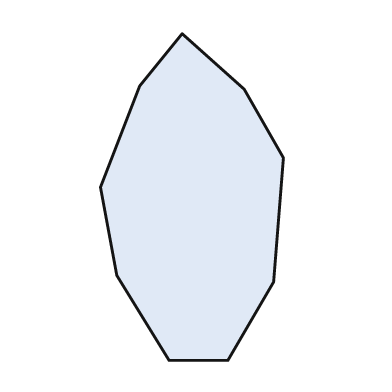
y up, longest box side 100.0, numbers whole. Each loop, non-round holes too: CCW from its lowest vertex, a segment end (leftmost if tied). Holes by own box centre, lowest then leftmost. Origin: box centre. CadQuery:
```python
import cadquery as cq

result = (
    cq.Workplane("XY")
    .moveTo(-7.0, -50.0)
    .lineTo(11.0, -50.0)
    .lineTo(25.0, -26.0)
    .lineTo(28.0, 12.0)
    .lineTo(16.0, 33.0)
    .lineTo(-3.0, 50.0)
    .lineTo(-16.0, 34.0)
    .lineTo(-28.0, 3.0)
    .lineTo(-23.0, -24.0)
    .close()
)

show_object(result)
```